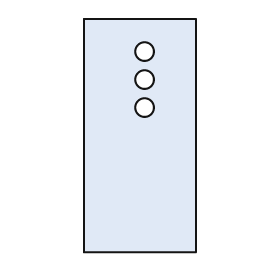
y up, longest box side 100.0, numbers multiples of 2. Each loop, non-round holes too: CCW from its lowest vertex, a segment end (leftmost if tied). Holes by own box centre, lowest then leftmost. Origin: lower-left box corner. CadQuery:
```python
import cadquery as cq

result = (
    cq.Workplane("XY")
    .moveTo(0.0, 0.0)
    .lineTo(48.0, 0.0)
    .lineTo(48.0, 100.0)
    .lineTo(0.0, 100.0)
    .close()
    .moveTo(26.0, 62.0)
    .circle(4.0)
    .moveTo(26.0, 74.0)
    .circle(4.0)
    .moveTo(26.0, 86.0)
    .circle(4.0)
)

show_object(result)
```